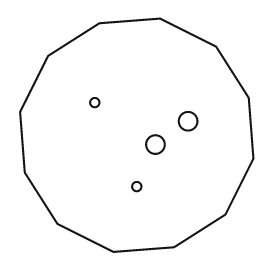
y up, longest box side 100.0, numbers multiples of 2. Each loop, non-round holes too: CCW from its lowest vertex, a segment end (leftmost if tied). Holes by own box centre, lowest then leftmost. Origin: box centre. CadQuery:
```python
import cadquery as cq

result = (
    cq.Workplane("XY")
    .moveTo(-10.0, -50.0)
    .lineTo(16.0, -48.0)
    .lineTo(38.0, -34.0)
    .lineTo(50.0, -10.0)
    .lineTo(48.0, 16.0)
    .lineTo(34.0, 38.0)
    .lineTo(10.0, 50.0)
    .lineTo(-16.0, 48.0)
    .lineTo(-38.0, 34.0)
    .lineTo(-50.0, 10.0)
    .lineTo(-48.0, -16.0)
    .lineTo(-34.0, -38.0)
    .close()
    .moveTo(0.0, -22.0)
    .circle(2.0)
    .moveTo(8.0, -4.0)
    .circle(4.0)
    .moveTo(22.0, 6.0)
    .circle(4.0)
    .moveTo(-18.0, 14.0)
    .circle(2.0)
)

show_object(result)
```